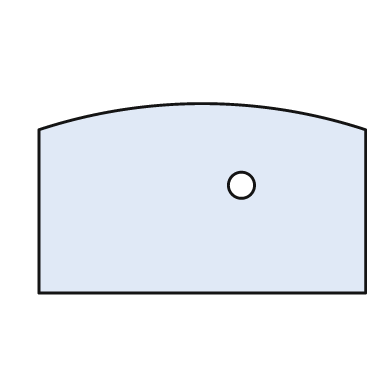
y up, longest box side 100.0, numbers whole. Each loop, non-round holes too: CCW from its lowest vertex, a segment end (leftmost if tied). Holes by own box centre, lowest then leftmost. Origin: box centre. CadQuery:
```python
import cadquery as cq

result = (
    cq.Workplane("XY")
    .moveTo(-50.0, -29.0)
    .lineTo(50.0, -29.0)
    .lineTo(50.0, 21.0)
    .threePointArc((0.0, 29.0), (-50.0, 21.0))
    .close()
    .moveTo(12.0, 4.0)
    .circle(4.0)
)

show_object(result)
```